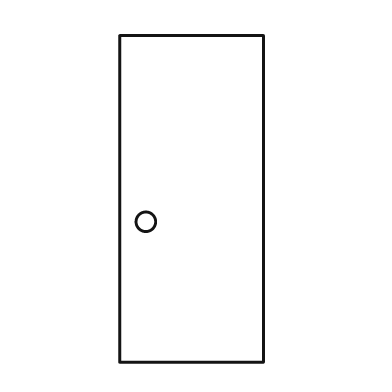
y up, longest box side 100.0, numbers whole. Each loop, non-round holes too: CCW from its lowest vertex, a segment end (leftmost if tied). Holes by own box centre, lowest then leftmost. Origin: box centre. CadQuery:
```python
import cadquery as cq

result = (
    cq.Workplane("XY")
    .moveTo(-22.0, -50.0)
    .lineTo(22.0, -50.0)
    .lineTo(22.0, 50.0)
    .lineTo(-22.0, 50.0)
    .close()
    .moveTo(-14.0, -7.0)
    .circle(3.0)
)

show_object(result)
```